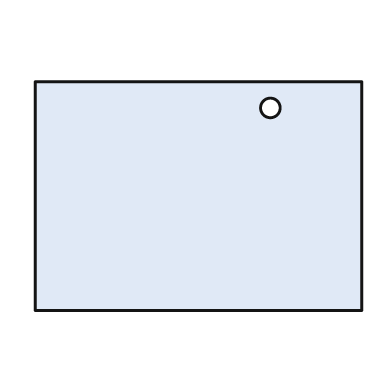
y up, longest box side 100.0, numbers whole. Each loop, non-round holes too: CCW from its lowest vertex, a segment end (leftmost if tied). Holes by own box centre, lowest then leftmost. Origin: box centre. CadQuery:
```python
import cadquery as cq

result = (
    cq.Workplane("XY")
    .moveTo(-50.0, -35.0)
    .lineTo(50.0, -35.0)
    .lineTo(50.0, 35.0)
    .lineTo(-50.0, 35.0)
    .close()
    .moveTo(22.0, 27.0)
    .circle(3.0)
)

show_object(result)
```